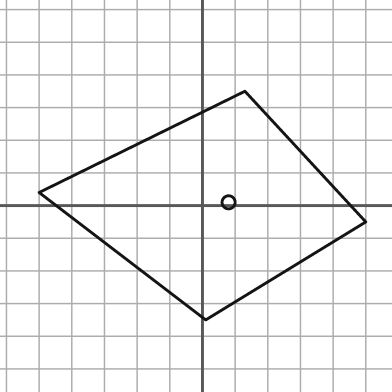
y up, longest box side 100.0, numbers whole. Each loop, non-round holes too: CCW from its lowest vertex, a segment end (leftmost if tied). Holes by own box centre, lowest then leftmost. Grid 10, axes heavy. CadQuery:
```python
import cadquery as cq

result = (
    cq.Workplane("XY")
    .moveTo(1.0, -35.0)
    .lineTo(50.0, -5.0)
    .lineTo(13.0, 35.0)
    .lineTo(-50.0, 4.0)
    .close()
    .moveTo(8.0, 1.0)
    .circle(2.0)
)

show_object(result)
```